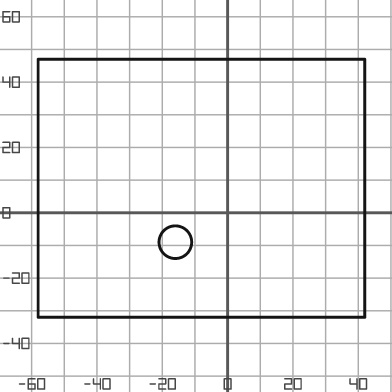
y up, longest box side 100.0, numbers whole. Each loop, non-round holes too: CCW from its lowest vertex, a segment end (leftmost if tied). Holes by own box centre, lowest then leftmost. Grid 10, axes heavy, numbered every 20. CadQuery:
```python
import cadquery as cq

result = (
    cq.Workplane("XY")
    .moveTo(-58.0, -32.0)
    .lineTo(42.0, -32.0)
    .lineTo(42.0, 47.0)
    .lineTo(-58.0, 47.0)
    .close()
    .moveTo(-16.0, -9.0)
    .circle(5.0)
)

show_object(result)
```